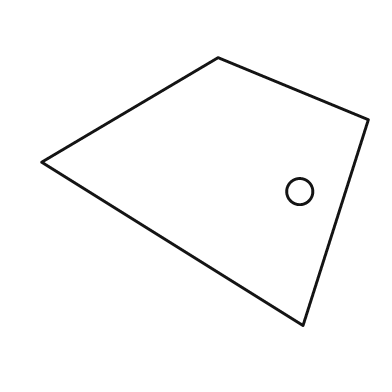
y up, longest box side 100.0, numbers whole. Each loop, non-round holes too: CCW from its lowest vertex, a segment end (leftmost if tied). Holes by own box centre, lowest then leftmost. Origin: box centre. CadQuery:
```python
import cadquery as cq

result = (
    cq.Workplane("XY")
    .moveTo(30.0, -41.0)
    .lineTo(50.0, 22.0)
    .lineTo(4.0, 41.0)
    .lineTo(-50.0, 9.0)
    .close()
    .moveTo(29.0, 0.0)
    .circle(4.0)
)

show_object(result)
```